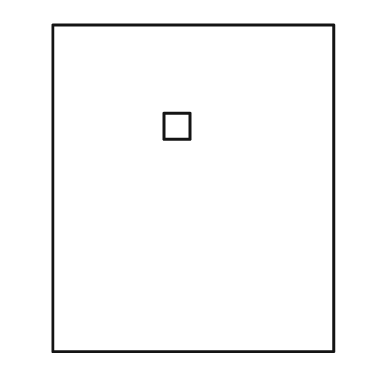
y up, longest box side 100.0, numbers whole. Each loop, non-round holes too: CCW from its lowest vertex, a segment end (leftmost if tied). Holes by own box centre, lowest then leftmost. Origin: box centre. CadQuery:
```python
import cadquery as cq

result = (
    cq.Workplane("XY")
    .moveTo(-43.0, -50.0)
    .lineTo(43.0, -50.0)
    .lineTo(43.0, 50.0)
    .lineTo(-43.0, 50.0)
    .close()
    .moveTo(-9.0, 15.0)
    .lineTo(-1.0, 15.0)
    .lineTo(-1.0, 23.0)
    .lineTo(-9.0, 23.0)
    .close()
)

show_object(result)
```